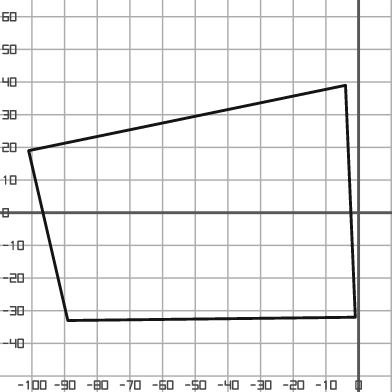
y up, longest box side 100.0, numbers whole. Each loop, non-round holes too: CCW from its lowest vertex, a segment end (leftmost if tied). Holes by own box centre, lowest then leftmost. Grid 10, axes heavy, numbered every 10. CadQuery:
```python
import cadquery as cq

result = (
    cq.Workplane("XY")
    .moveTo(-89.0, -33.0)
    .lineTo(-1.0, -32.0)
    .lineTo(-4.0, 39.0)
    .lineTo(-101.0, 19.0)
    .close()
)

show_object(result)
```